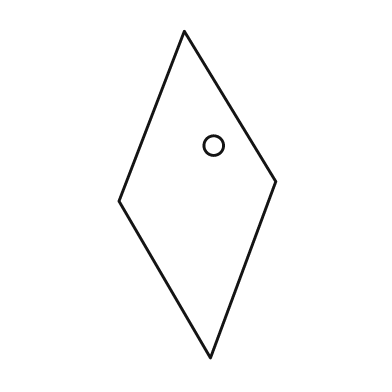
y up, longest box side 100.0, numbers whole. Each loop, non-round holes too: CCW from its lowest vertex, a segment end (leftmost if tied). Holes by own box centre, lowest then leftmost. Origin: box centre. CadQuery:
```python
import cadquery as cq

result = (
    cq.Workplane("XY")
    .moveTo(4.0, -50.0)
    .lineTo(24.0, 4.0)
    .lineTo(-4.0, 50.0)
    .lineTo(-24.0, -2.0)
    .close()
    .moveTo(5.0, 15.0)
    .circle(3.0)
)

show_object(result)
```